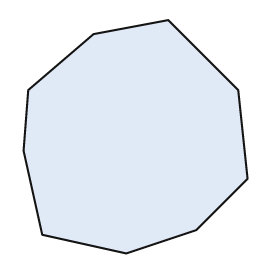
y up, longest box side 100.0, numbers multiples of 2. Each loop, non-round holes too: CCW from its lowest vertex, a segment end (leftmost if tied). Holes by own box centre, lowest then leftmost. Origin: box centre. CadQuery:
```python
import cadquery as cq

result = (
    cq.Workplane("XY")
    .moveTo(-4.0, -50.0)
    .lineTo(26.0, -40.0)
    .lineTo(48.0, -18.0)
    .lineTo(44.0, 20.0)
    .lineTo(14.0, 50.0)
    .lineTo(-18.0, 44.0)
    .lineTo(-46.0, 20.0)
    .lineTo(-48.0, -6.0)
    .lineTo(-40.0, -42.0)
    .close()
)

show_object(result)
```